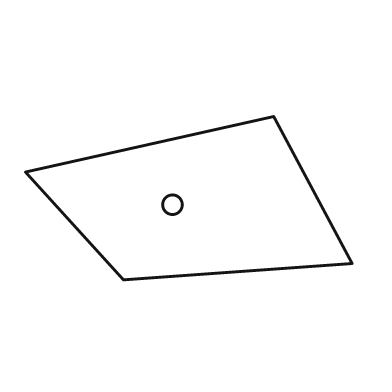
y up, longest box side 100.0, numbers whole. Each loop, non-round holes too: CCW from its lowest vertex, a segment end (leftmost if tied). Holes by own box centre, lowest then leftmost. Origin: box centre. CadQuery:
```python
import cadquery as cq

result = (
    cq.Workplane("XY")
    .moveTo(-20.0, -25.0)
    .lineTo(50.0, -20.0)
    .lineTo(26.0, 25.0)
    .lineTo(-50.0, 8.0)
    .close()
    .moveTo(-5.0, -2.0)
    .circle(3.0)
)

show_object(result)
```